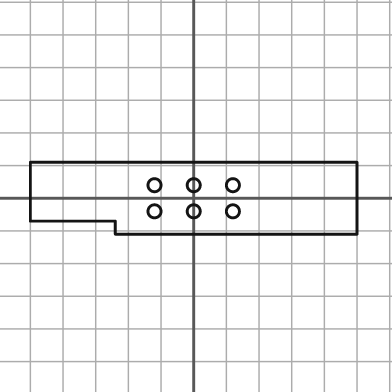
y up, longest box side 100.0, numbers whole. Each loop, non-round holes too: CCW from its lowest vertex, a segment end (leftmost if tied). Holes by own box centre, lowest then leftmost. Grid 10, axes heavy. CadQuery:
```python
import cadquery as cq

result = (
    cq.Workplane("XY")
    .moveTo(-24.0, -11.0)
    .lineTo(50.0, -11.0)
    .lineTo(50.0, 11.0)
    .lineTo(-50.0, 11.0)
    .lineTo(-50.0, -7.0)
    .lineTo(-24.0, -7.0)
    .close()
    .moveTo(-12.0, -4.0)
    .circle(2.0)
    .moveTo(0.0, -4.0)
    .circle(2.0)
    .moveTo(12.0, -4.0)
    .circle(2.0)
    .moveTo(-12.0, 4.0)
    .circle(2.0)
    .moveTo(0.0, 4.0)
    .circle(2.0)
    .moveTo(12.0, 4.0)
    .circle(2.0)
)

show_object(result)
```